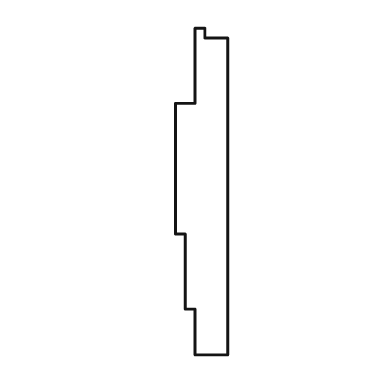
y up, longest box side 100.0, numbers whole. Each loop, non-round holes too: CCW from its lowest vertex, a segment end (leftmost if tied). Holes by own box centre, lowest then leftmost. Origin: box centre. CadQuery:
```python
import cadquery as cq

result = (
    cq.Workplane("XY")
    .moveTo(-2.0, -50.0)
    .lineTo(8.0, -50.0)
    .lineTo(8.0, 47.0)
    .lineTo(1.0, 47.0)
    .lineTo(1.0, 50.0)
    .lineTo(-2.0, 50.0)
    .lineTo(-2.0, 27.0)
    .lineTo(-8.0, 27.0)
    .lineTo(-8.0, -13.0)
    .lineTo(-5.0, -13.0)
    .lineTo(-5.0, -36.0)
    .lineTo(-2.0, -36.0)
    .close()
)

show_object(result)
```